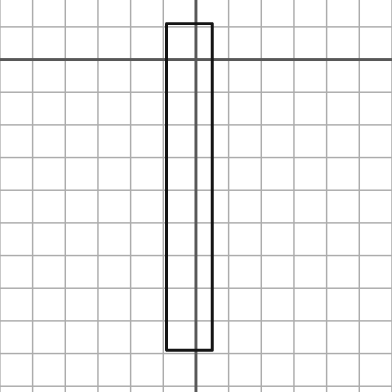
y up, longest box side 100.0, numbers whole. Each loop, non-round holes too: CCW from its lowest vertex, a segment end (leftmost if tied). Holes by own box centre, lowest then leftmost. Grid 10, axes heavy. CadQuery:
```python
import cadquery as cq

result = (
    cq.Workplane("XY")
    .moveTo(-9.0, -89.0)
    .lineTo(5.0, -89.0)
    .lineTo(5.0, 11.0)
    .lineTo(-9.0, 11.0)
    .close()
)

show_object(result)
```